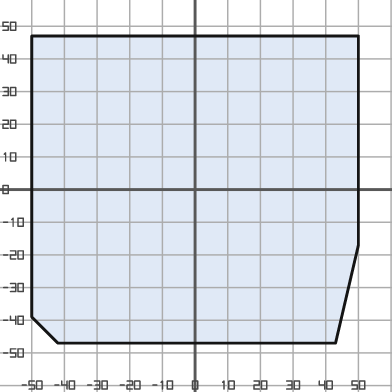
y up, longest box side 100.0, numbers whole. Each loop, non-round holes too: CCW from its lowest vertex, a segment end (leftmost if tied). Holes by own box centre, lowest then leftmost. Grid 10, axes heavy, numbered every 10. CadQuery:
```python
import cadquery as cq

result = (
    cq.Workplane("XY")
    .moveTo(-42.0, -47.0)
    .lineTo(43.0, -47.0)
    .lineTo(50.0, -17.0)
    .lineTo(50.0, 47.0)
    .lineTo(-50.0, 47.0)
    .lineTo(-50.0, -39.0)
    .close()
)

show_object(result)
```